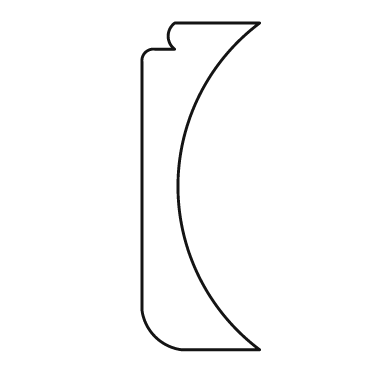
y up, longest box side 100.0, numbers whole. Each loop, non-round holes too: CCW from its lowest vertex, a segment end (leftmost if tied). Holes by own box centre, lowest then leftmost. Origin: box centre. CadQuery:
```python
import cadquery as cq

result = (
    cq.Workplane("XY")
    .moveTo(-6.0, -50.0)
    .lineTo(18.0, -50.0)
    .threePointArc((-7.0, 0.0), (18.0, 50.0))
    .lineTo(-8.0, 50.0)
    .threePointArc((-10.0, 46.0), (-8.0, 42.0))
    .lineTo(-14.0, 42.0)
    .threePointArc((-17.0, 41.0), (-18.0, 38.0))
    .lineTo(-18.0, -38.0)
    .threePointArc((-14.0, -46.0), (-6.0, -50.0))
    .close()
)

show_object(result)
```